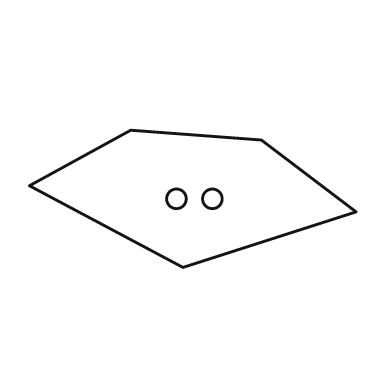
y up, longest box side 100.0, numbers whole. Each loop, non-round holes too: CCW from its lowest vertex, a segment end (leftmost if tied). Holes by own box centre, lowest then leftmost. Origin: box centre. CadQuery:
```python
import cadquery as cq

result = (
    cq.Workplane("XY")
    .moveTo(-3.0, -21.0)
    .lineTo(50.0, -4.0)
    .lineTo(21.0, 18.0)
    .lineTo(-19.0, 21.0)
    .lineTo(-50.0, 4.0)
    .close()
    .moveTo(-5.0, 0.0)
    .circle(3.0)
    .moveTo(6.0, 0.0)
    .circle(3.0)
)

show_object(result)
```